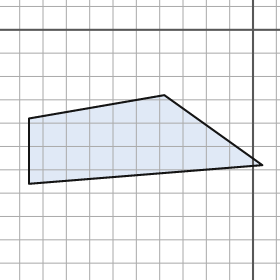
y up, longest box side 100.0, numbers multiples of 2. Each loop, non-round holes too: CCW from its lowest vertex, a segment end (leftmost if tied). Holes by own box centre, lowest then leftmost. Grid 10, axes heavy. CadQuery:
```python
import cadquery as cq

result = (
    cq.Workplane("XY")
    .moveTo(-96.0, -66.0)
    .lineTo(4.0, -58.0)
    .lineTo(-38.0, -28.0)
    .lineTo(-96.0, -38.0)
    .close()
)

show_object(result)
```